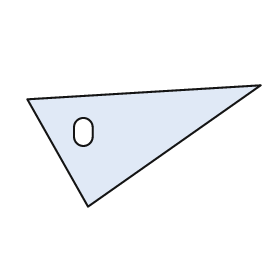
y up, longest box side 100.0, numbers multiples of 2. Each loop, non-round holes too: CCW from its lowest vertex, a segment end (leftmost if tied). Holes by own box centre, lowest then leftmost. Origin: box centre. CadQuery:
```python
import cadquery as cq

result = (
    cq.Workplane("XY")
    .moveTo(-24.0, -26.0)
    .lineTo(50.0, 26.0)
    .lineTo(-50.0, 20.0)
    .close()
    .moveTo(-30.0, 4.0)
    .threePointArc((-26.0, 0.0), (-22.0, 4.0))
    .lineTo(-22.0, 8.0)
    .threePointArc((-26.0, 12.0), (-30.0, 8.0))
    .close()
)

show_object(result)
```